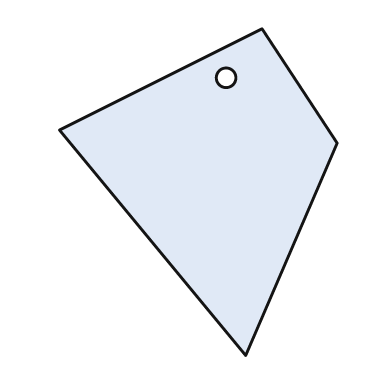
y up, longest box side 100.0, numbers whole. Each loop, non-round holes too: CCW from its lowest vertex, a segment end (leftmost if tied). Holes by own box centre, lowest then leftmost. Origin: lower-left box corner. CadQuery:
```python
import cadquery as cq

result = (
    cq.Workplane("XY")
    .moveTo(57.0, 0.0)
    .lineTo(85.0, 65.0)
    .lineTo(62.0, 100.0)
    .lineTo(0.0, 69.0)
    .close()
    .moveTo(51.0, 85.0)
    .circle(3.0)
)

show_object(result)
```